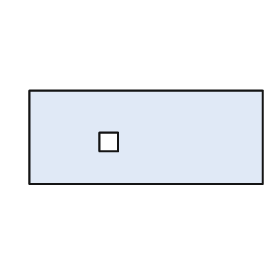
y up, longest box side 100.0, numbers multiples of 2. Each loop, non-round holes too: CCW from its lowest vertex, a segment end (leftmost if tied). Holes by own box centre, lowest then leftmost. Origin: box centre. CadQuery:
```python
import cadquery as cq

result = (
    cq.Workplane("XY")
    .moveTo(-50.0, -20.0)
    .lineTo(50.0, -20.0)
    .lineTo(50.0, 20.0)
    .lineTo(-50.0, 20.0)
    .close()
    .moveTo(-20.0, -6.0)
    .lineTo(-12.0, -6.0)
    .lineTo(-12.0, 2.0)
    .lineTo(-20.0, 2.0)
    .close()
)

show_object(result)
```